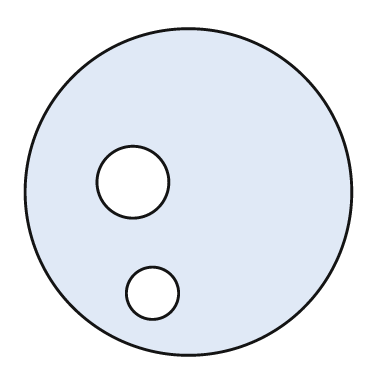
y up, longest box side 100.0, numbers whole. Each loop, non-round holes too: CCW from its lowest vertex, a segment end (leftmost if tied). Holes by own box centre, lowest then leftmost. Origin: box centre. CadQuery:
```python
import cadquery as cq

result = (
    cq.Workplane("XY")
    .moveTo(0.0, 0.0)
    .circle(50.0)
    .moveTo(-11.0, -31.0)
    .circle(8.0)
    .moveTo(-17.0, 3.0)
    .circle(11.0)
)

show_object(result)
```